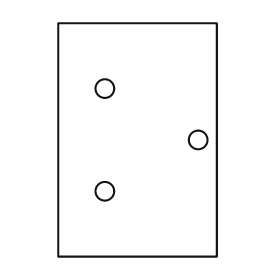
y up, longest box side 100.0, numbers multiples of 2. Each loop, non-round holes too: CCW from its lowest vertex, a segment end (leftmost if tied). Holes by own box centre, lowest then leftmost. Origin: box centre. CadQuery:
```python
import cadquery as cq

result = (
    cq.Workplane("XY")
    .moveTo(-34.0, -50.0)
    .lineTo(34.0, -50.0)
    .lineTo(34.0, 50.0)
    .lineTo(-34.0, 50.0)
    .close()
    .moveTo(-14.0, -22.0)
    .circle(4.0)
    .moveTo(26.0, 0.0)
    .circle(4.0)
    .moveTo(-14.0, 22.0)
    .circle(4.0)
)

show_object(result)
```